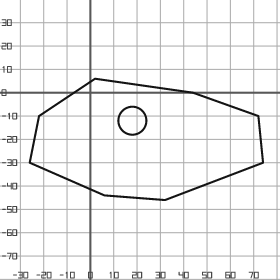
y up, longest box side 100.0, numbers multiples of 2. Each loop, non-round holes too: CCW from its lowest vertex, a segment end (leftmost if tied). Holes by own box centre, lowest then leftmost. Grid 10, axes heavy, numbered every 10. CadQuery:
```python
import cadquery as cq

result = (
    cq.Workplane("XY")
    .moveTo(32.0, -46.0)
    .lineTo(74.0, -30.0)
    .lineTo(72.0, -10.0)
    .lineTo(44.0, 0.0)
    .lineTo(2.0, 6.0)
    .lineTo(-22.0, -10.0)
    .lineTo(-26.0, -30.0)
    .lineTo(6.0, -44.0)
    .close()
    .moveTo(18.0, -12.0)
    .circle(6.0)
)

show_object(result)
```